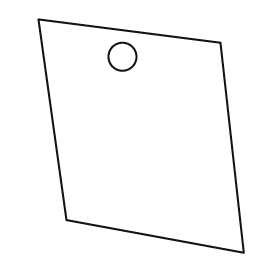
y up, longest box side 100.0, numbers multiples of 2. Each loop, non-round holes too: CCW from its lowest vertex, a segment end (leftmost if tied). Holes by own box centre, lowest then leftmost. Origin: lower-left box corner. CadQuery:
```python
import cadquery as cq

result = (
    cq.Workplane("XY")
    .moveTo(88.0, 0.0)
    .lineTo(78.0, 90.0)
    .lineTo(0.0, 100.0)
    .lineTo(12.0, 14.0)
    .close()
    .moveTo(36.0, 84.0)
    .circle(6.0)
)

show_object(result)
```